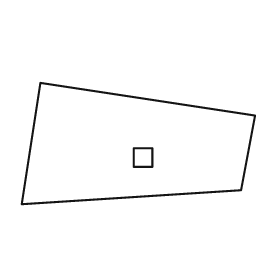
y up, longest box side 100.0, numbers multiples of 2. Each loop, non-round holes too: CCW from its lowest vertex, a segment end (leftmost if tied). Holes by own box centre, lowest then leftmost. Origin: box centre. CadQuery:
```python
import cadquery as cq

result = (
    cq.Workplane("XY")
    .moveTo(-50.0, -26.0)
    .lineTo(44.0, -20.0)
    .lineTo(50.0, 12.0)
    .lineTo(-42.0, 26.0)
    .close()
    .moveTo(-2.0, -10.0)
    .lineTo(6.0, -10.0)
    .lineTo(6.0, -2.0)
    .lineTo(-2.0, -2.0)
    .close()
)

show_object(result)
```